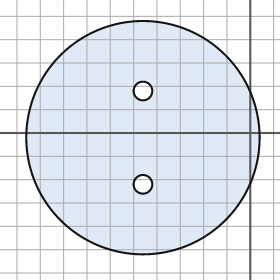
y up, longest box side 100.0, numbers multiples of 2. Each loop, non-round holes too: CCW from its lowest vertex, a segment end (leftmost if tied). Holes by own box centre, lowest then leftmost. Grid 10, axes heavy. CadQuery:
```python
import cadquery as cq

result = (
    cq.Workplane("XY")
    .moveTo(-46.0, -2.0)
    .circle(50.0)
    .moveTo(-46.0, -22.0)
    .circle(4.0)
    .moveTo(-46.0, 18.0)
    .circle(4.0)
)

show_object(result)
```